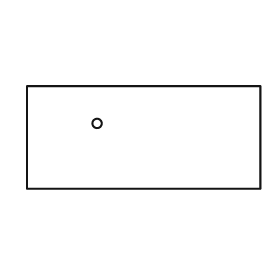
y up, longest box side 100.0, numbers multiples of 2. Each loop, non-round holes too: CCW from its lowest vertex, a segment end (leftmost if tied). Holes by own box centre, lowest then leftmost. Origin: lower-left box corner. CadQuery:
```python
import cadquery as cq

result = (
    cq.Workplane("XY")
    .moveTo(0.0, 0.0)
    .lineTo(100.0, 0.0)
    .lineTo(100.0, 44.0)
    .lineTo(0.0, 44.0)
    .close()
    .moveTo(30.0, 28.0)
    .circle(2.0)
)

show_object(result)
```